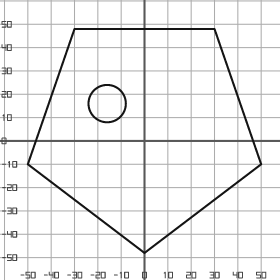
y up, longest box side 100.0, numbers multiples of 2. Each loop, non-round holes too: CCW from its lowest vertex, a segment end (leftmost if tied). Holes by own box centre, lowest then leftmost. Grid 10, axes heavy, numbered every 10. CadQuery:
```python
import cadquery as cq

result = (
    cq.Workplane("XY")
    .moveTo(0.0, -48.0)
    .lineTo(50.0, -10.0)
    .lineTo(30.0, 48.0)
    .lineTo(-30.0, 48.0)
    .lineTo(-50.0, -10.0)
    .close()
    .moveTo(-16.0, 16.0)
    .circle(8.0)
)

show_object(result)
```